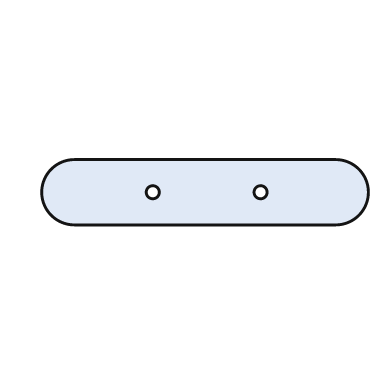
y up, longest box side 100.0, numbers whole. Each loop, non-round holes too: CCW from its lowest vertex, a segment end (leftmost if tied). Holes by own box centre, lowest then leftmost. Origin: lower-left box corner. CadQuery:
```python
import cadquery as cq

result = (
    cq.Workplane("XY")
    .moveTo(10.0, 0.0)
    .lineTo(90.0, 0.0)
    .threePointArc((100.0, 10.0), (90.0, 20.0))
    .lineTo(10.0, 20.0)
    .threePointArc((0.0, 10.0), (10.0, 0.0))
    .close()
    .moveTo(34.0, 10.0)
    .circle(2.0)
    .moveTo(67.0, 10.0)
    .circle(2.0)
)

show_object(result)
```